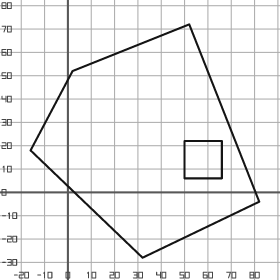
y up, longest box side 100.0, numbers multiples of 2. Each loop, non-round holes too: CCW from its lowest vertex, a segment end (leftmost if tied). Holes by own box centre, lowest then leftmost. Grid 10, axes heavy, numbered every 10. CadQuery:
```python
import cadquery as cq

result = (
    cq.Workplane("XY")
    .moveTo(32.0, -28.0)
    .lineTo(82.0, -4.0)
    .lineTo(52.0, 72.0)
    .lineTo(2.0, 52.0)
    .lineTo(-16.0, 18.0)
    .close()
    .moveTo(50.0, 6.0)
    .lineTo(66.0, 6.0)
    .lineTo(66.0, 22.0)
    .lineTo(50.0, 22.0)
    .close()
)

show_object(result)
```